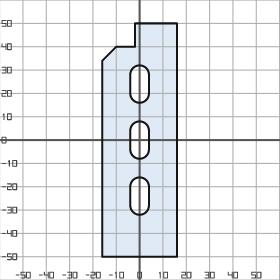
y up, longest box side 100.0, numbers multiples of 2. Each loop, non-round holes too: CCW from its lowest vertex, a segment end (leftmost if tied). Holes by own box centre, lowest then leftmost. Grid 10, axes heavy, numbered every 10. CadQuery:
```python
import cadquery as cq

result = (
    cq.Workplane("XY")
    .moveTo(-16.0, -50.0)
    .lineTo(16.0, -50.0)
    .lineTo(16.0, 50.0)
    .lineTo(-2.0, 50.0)
    .lineTo(-2.0, 40.0)
    .lineTo(-10.0, 40.0)
    .lineTo(-16.0, 34.0)
    .close()
    .moveTo(-4.0, -28.0)
    .threePointArc((0.0, -32.0), (4.0, -28.0))
    .lineTo(4.0, -20.0)
    .threePointArc((0.0, -16.0), (-4.0, -20.0))
    .close()
    .moveTo(-4.0, -4.0)
    .threePointArc((0.0, -8.0), (4.0, -4.0))
    .lineTo(4.0, 4.0)
    .threePointArc((0.0, 8.0), (-4.0, 4.0))
    .close()
    .moveTo(-4.0, 20.0)
    .threePointArc((0.0, 16.0), (4.0, 20.0))
    .lineTo(4.0, 28.0)
    .threePointArc((0.0, 32.0), (-4.0, 28.0))
    .close()
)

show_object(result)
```